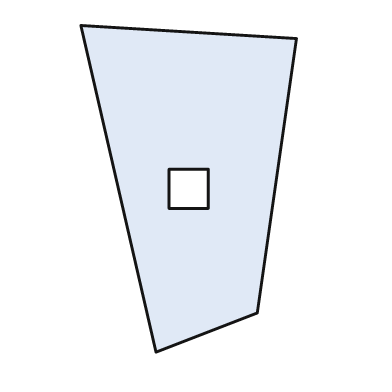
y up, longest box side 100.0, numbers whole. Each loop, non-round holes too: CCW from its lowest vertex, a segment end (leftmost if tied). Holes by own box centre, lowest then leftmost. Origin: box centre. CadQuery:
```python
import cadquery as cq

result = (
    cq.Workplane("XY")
    .moveTo(-10.0, -50.0)
    .lineTo(21.0, -38.0)
    .lineTo(33.0, 46.0)
    .lineTo(-33.0, 50.0)
    .close()
    .moveTo(-6.0, -6.0)
    .lineTo(6.0, -6.0)
    .lineTo(6.0, 6.0)
    .lineTo(-6.0, 6.0)
    .close()
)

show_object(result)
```